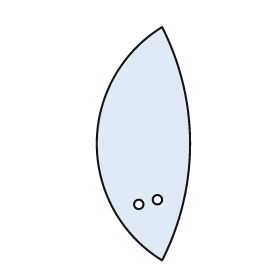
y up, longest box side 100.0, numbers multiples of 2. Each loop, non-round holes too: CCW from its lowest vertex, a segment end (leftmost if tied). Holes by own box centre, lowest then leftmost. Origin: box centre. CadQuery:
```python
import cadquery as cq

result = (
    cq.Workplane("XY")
    .moveTo(8.0, -50.0)
    .threePointArc((20.0, 0.0), (8.0, 50.0))
    .threePointArc((-20.0, 0.0), (8.0, -50.0))
    .close()
    .moveTo(-2.0, -26.0)
    .circle(2.0)
    .moveTo(6.0, -24.0)
    .circle(2.0)
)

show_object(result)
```